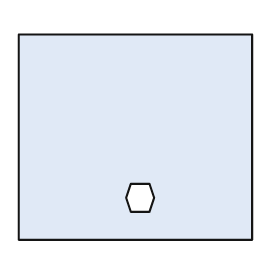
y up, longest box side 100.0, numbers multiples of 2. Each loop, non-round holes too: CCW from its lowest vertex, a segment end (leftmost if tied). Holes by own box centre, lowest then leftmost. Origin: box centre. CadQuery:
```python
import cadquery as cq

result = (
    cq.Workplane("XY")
    .moveTo(-50.0, -44.0)
    .lineTo(50.0, -44.0)
    .lineTo(50.0, 44.0)
    .lineTo(-50.0, 44.0)
    .close()
    .moveTo(-2.0, -32.0)
    .lineTo(6.0, -32.0)
    .lineTo(8.0, -26.0)
    .lineTo(6.0, -20.0)
    .lineTo(-2.0, -20.0)
    .lineTo(-4.0, -26.0)
    .close()
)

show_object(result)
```